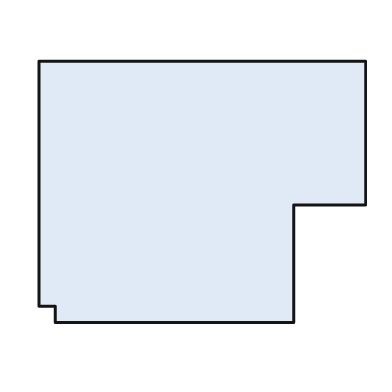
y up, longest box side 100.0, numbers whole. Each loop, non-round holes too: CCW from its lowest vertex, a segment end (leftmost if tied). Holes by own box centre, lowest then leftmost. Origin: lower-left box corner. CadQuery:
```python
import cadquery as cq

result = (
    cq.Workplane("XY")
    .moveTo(5.0, 0.0)
    .lineTo(78.0, 0.0)
    .lineTo(78.0, 36.0)
    .lineTo(100.0, 36.0)
    .lineTo(100.0, 80.0)
    .lineTo(0.0, 80.0)
    .lineTo(0.0, 5.0)
    .lineTo(5.0, 5.0)
    .close()
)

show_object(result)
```